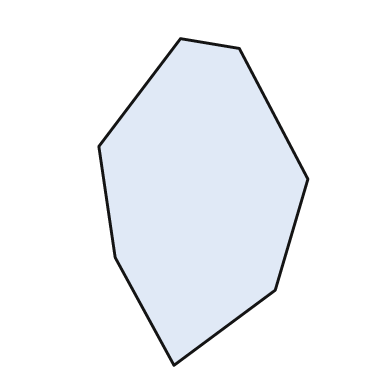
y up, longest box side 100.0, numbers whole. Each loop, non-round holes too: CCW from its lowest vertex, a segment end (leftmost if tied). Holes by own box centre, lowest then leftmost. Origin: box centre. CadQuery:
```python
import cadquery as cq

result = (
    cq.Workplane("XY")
    .moveTo(-9.0, -50.0)
    .lineTo(22.0, -27.0)
    .lineTo(32.0, 7.0)
    .lineTo(11.0, 47.0)
    .lineTo(-7.0, 50.0)
    .lineTo(-32.0, 17.0)
    .lineTo(-27.0, -17.0)
    .close()
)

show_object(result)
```